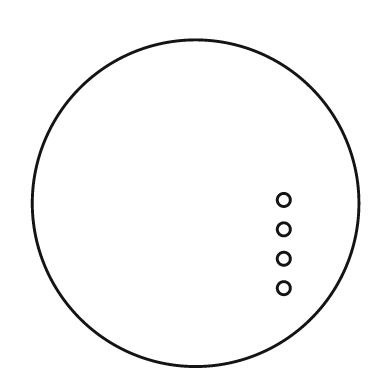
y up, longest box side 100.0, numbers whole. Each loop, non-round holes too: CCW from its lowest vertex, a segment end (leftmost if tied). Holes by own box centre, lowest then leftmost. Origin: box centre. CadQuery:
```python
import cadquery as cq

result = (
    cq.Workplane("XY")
    .moveTo(0.0, 0.0)
    .circle(50.0)
    .moveTo(27.0, -26.0)
    .circle(2.0)
    .moveTo(27.0, -17.0)
    .circle(2.0)
    .moveTo(27.0, -8.0)
    .circle(2.0)
    .moveTo(27.0, 1.0)
    .circle(2.0)
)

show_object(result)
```